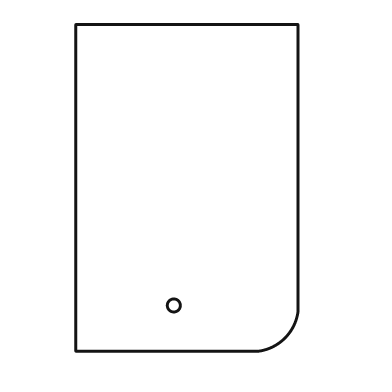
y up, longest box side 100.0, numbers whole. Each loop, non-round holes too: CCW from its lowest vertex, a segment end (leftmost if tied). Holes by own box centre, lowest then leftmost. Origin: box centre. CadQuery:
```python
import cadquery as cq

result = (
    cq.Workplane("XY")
    .moveTo(-34.0, -50.0)
    .lineTo(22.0, -50.0)
    .threePointArc((30.0, -46.0), (34.0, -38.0))
    .lineTo(34.0, 50.0)
    .lineTo(-34.0, 50.0)
    .close()
    .moveTo(-4.0, -36.0)
    .circle(2.0)
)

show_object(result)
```